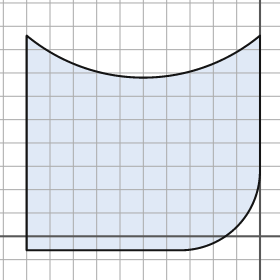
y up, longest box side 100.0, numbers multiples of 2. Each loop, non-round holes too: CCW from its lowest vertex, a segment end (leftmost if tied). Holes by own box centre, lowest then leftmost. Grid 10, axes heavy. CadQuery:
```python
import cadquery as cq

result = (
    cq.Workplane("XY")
    .moveTo(-100.0, -6.0)
    .lineTo(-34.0, -6.0)
    .threePointArc((-10.0, 4.0), (0.0, 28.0))
    .lineTo(0.0, 86.0)
    .threePointArc((-50.0, 68.0), (-100.0, 86.0))
    .close()
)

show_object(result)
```